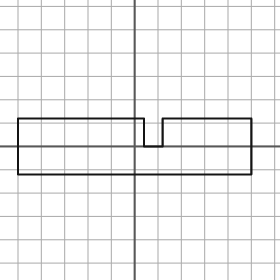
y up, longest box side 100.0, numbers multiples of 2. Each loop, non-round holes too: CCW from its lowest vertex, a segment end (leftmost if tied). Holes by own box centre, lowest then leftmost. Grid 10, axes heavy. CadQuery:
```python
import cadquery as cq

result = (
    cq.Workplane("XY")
    .moveTo(-50.0, -12.0)
    .lineTo(50.0, -12.0)
    .lineTo(50.0, 12.0)
    .lineTo(12.0, 12.0)
    .lineTo(12.0, 0.0)
    .lineTo(4.0, 0.0)
    .lineTo(4.0, 12.0)
    .lineTo(-50.0, 12.0)
    .close()
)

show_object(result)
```